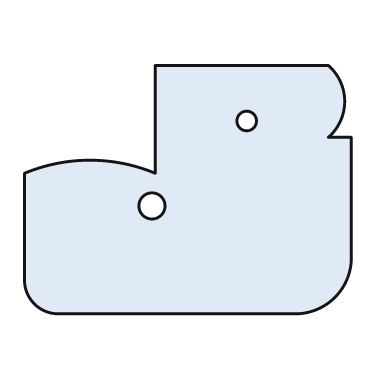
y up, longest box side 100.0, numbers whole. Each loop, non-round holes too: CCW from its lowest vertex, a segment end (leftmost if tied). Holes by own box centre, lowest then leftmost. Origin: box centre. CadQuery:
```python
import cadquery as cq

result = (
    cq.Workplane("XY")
    .moveTo(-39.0, -38.0)
    .lineTo(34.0, -38.0)
    .threePointArc((45.0, -33.0), (50.0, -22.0))
    .lineTo(50.0, 16.0)
    .lineTo(43.0, 16.0)
    .threePointArc((48.0, 27.0), (43.0, 38.0))
    .lineTo(-10.0, 38.0)
    .lineTo(-10.0, 5.0)
    .threePointArc((-30.0, 9.0), (-50.0, 5.0))
    .lineTo(-50.0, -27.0)
    .threePointArc((-47.0, -35.0), (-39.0, -38.0))
    .close()
    .moveTo(-11.0, -5.0)
    .circle(4.0)
    .moveTo(18.0, 21.0)
    .circle(3.0)
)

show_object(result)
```